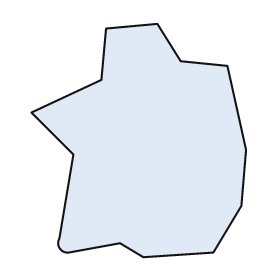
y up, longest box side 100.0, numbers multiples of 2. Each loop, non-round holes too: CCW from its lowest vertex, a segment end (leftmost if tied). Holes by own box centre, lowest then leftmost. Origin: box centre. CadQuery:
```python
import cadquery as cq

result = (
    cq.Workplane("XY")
    .moveTo(2.0, -50.0)
    .lineTo(32.0, -48.0)
    .lineTo(44.0, -28.0)
    .lineTo(46.0, -4.0)
    .lineTo(38.0, 32.0)
    .lineTo(18.0, 34.0)
    .lineTo(8.0, 50.0)
    .lineTo(-14.0, 48.0)
    .lineTo(-16.0, 26.0)
    .lineTo(-46.0, 12.0)
    .lineTo(-28.0, -6.0)
    .lineTo(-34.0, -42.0)
    .threePointArc((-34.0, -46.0), (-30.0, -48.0))
    .lineTo(-8.0, -44.0)
    .close()
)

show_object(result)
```